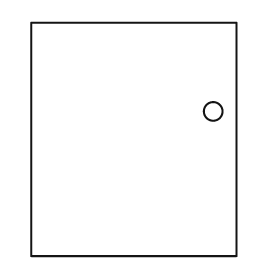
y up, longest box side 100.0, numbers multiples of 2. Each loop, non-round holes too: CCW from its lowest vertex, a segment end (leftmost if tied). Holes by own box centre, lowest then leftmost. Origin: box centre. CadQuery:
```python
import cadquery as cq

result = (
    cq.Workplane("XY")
    .moveTo(-44.0, -50.0)
    .lineTo(44.0, -50.0)
    .lineTo(44.0, 50.0)
    .lineTo(-44.0, 50.0)
    .close()
    .moveTo(34.0, 12.0)
    .circle(4.0)
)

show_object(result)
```